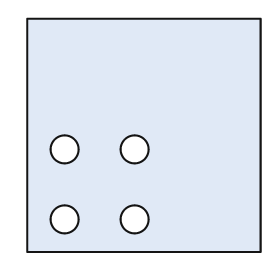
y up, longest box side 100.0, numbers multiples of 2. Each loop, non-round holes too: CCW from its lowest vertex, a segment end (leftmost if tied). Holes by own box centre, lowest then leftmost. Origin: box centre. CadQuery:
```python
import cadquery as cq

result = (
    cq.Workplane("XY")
    .moveTo(-50.0, -50.0)
    .lineTo(50.0, -50.0)
    .lineTo(50.0, 50.0)
    .lineTo(-50.0, 50.0)
    .close()
    .moveTo(-34.0, -36.0)
    .circle(6.0)
    .moveTo(-4.0, -36.0)
    .circle(6.0)
    .moveTo(-34.0, -6.0)
    .circle(6.0)
    .moveTo(-4.0, -6.0)
    .circle(6.0)
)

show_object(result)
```